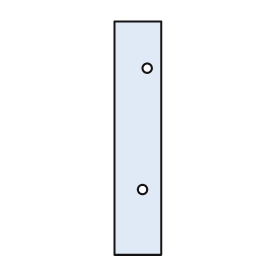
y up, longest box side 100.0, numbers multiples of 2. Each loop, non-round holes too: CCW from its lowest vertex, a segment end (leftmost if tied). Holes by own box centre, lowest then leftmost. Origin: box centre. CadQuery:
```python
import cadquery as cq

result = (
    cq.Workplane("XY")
    .moveTo(-10.0, -50.0)
    .lineTo(10.0, -50.0)
    .lineTo(10.0, 50.0)
    .lineTo(-10.0, 50.0)
    .close()
    .moveTo(2.0, -22.0)
    .circle(2.0)
    .moveTo(4.0, 30.0)
    .circle(2.0)
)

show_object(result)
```